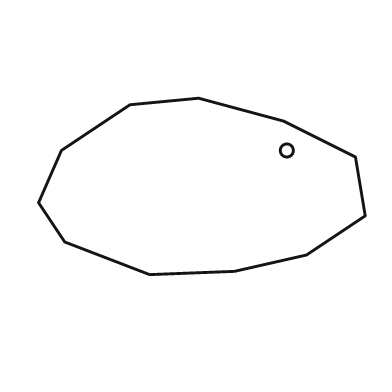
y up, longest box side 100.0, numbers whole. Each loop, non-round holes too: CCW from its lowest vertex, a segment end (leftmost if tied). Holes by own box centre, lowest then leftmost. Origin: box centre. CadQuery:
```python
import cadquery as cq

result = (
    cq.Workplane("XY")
    .moveTo(-16.0, -27.0)
    .lineTo(10.0, -26.0)
    .lineTo(32.0, -21.0)
    .lineTo(50.0, -9.0)
    .lineTo(47.0, 9.0)
    .lineTo(25.0, 20.0)
    .lineTo(-1.0, 27.0)
    .lineTo(-22.0, 25.0)
    .lineTo(-43.0, 11.0)
    .lineTo(-50.0, -5.0)
    .lineTo(-42.0, -17.0)
    .close()
    .moveTo(26.0, 11.0)
    .circle(2.0)
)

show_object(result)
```